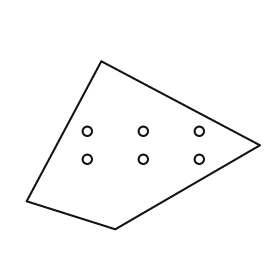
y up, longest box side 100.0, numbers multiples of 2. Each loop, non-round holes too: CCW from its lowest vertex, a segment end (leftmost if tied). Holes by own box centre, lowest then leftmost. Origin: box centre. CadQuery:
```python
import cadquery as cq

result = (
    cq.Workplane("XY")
    .moveTo(-12.0, -36.0)
    .lineTo(50.0, 0.0)
    .lineTo(-18.0, 36.0)
    .lineTo(-50.0, -24.0)
    .close()
    .moveTo(-24.0, -6.0)
    .circle(2.0)
    .moveTo(0.0, -6.0)
    .circle(2.0)
    .moveTo(24.0, -6.0)
    .circle(2.0)
    .moveTo(-24.0, 6.0)
    .circle(2.0)
    .moveTo(0.0, 6.0)
    .circle(2.0)
    .moveTo(24.0, 6.0)
    .circle(2.0)
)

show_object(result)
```